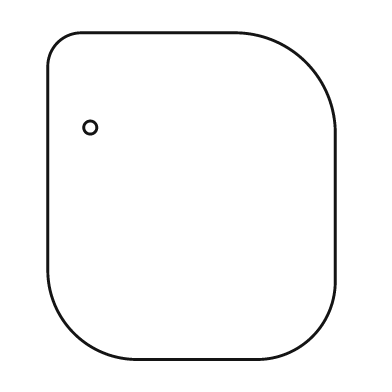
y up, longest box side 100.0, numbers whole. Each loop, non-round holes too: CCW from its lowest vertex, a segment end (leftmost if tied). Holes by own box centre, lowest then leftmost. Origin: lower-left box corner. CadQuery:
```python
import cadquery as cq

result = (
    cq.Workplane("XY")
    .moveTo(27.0, 0.0)
    .lineTo(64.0, 0.0)
    .threePointArc((81.0, 7.0), (88.0, 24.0))
    .lineTo(88.0, 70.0)
    .threePointArc((79.0, 91.0), (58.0, 100.0))
    .lineTo(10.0, 100.0)
    .threePointArc((3.0, 97.0), (0.0, 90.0))
    .lineTo(0.0, 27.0)
    .threePointArc((8.0, 8.0), (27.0, 0.0))
    .close()
    .moveTo(13.0, 71.0)
    .circle(2.0)
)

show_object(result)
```